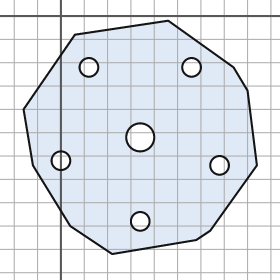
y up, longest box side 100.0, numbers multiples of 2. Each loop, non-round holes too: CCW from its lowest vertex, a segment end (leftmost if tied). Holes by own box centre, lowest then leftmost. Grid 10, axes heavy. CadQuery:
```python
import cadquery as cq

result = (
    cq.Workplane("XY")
    .moveTo(22.0, -102.0)
    .lineTo(58.0, -96.0)
    .lineTo(64.0, -92.0)
    .lineTo(84.0, -64.0)
    .lineTo(80.0, -32.0)
    .lineTo(74.0, -22.0)
    .lineTo(46.0, -2.0)
    .lineTo(6.0, -8.0)
    .lineTo(-16.0, -40.0)
    .lineTo(-12.0, -64.0)
    .lineTo(4.0, -90.0)
    .close()
    .moveTo(34.0, -88.0)
    .circle(4.0)
    .moveTo(68.0, -64.0)
    .circle(4.0)
    .moveTo(0.0, -62.0)
    .circle(4.0)
    .moveTo(34.0, -52.0)
    .circle(6.0)
    .moveTo(12.0, -22.0)
    .circle(4.0)
    .moveTo(56.0, -22.0)
    .circle(4.0)
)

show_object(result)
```